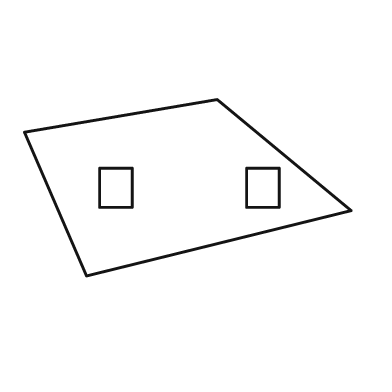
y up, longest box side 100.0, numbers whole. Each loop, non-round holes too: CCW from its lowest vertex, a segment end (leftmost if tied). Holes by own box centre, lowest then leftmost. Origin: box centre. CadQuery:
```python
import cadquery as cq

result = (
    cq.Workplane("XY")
    .moveTo(-31.0, -27.0)
    .lineTo(50.0, -7.0)
    .lineTo(9.0, 27.0)
    .lineTo(-50.0, 17.0)
    .close()
    .moveTo(-27.0, -6.0)
    .lineTo(-17.0, -6.0)
    .lineTo(-17.0, 6.0)
    .lineTo(-27.0, 6.0)
    .close()
    .moveTo(18.0, -6.0)
    .lineTo(28.0, -6.0)
    .lineTo(28.0, 6.0)
    .lineTo(18.0, 6.0)
    .close()
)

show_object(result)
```